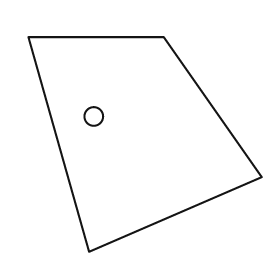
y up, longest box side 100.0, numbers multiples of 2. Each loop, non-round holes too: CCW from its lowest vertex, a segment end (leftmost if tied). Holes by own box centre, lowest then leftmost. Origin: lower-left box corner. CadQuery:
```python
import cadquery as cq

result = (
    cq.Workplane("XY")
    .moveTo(26.0, 0.0)
    .lineTo(100.0, 32.0)
    .lineTo(58.0, 92.0)
    .lineTo(0.0, 92.0)
    .close()
    .moveTo(28.0, 58.0)
    .circle(4.0)
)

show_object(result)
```